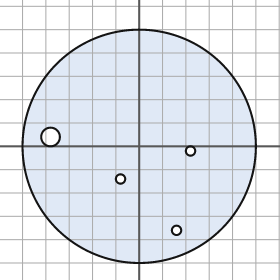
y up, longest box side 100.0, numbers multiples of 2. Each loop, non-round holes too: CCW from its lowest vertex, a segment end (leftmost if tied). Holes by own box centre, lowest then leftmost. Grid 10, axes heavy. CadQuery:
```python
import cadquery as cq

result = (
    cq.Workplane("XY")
    .moveTo(0.0, 0.0)
    .circle(50.0)
    .moveTo(16.0, -36.0)
    .circle(2.0)
    .moveTo(-8.0, -14.0)
    .circle(2.0)
    .moveTo(22.0, -2.0)
    .circle(2.0)
    .moveTo(-38.0, 4.0)
    .circle(4.0)
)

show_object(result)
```